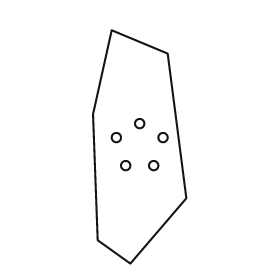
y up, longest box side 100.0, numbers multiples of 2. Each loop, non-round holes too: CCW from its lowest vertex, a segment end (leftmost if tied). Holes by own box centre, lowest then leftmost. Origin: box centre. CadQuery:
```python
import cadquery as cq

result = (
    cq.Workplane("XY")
    .moveTo(-4.0, -50.0)
    .lineTo(20.0, -22.0)
    .lineTo(12.0, 40.0)
    .lineTo(-12.0, 50.0)
    .lineTo(-20.0, 14.0)
    .lineTo(-18.0, -40.0)
    .close()
    .moveTo(-6.0, -8.0)
    .circle(2.0)
    .moveTo(6.0, -8.0)
    .circle(2.0)
    .moveTo(-10.0, 4.0)
    .circle(2.0)
    .moveTo(10.0, 4.0)
    .circle(2.0)
    .moveTo(0.0, 10.0)
    .circle(2.0)
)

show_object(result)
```